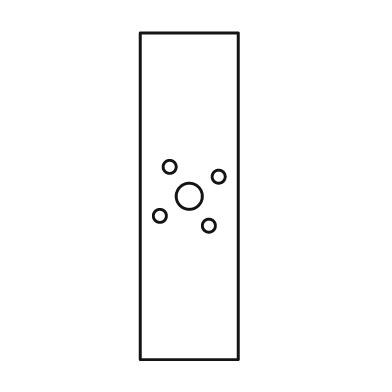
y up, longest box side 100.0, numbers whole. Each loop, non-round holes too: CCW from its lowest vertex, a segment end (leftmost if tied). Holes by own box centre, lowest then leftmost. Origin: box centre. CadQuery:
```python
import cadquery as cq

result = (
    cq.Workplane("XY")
    .moveTo(-15.0, -50.0)
    .lineTo(15.0, -50.0)
    .lineTo(15.0, 50.0)
    .lineTo(-15.0, 50.0)
    .close()
    .moveTo(6.0, -9.0)
    .circle(2.0)
    .moveTo(-9.0, -6.0)
    .circle(2.0)
    .moveTo(0.0, 0.0)
    .circle(4.0)
    .moveTo(9.0, 6.0)
    .circle(2.0)
    .moveTo(-6.0, 9.0)
    .circle(2.0)
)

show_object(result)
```